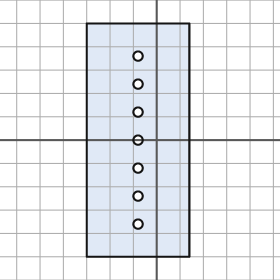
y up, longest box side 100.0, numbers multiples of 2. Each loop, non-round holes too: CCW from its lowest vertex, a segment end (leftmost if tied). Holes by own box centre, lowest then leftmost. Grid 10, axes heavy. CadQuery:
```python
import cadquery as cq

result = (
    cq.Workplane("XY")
    .moveTo(-30.0, -50.0)
    .lineTo(14.0, -50.0)
    .lineTo(14.0, 50.0)
    .lineTo(-30.0, 50.0)
    .close()
    .moveTo(-8.0, -36.0)
    .circle(2.0)
    .moveTo(-8.0, -24.0)
    .circle(2.0)
    .moveTo(-8.0, -12.0)
    .circle(2.0)
    .moveTo(-8.0, 0.0)
    .circle(2.0)
    .moveTo(-8.0, 12.0)
    .circle(2.0)
    .moveTo(-8.0, 24.0)
    .circle(2.0)
    .moveTo(-8.0, 36.0)
    .circle(2.0)
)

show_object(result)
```